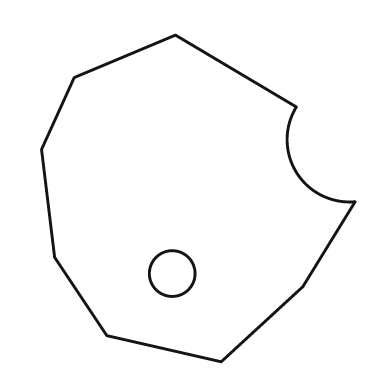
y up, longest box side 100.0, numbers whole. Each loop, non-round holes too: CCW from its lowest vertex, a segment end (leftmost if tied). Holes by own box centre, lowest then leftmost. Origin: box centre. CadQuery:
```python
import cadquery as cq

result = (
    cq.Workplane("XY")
    .moveTo(7.0, -50.0)
    .lineTo(32.0, -27.0)
    .lineTo(48.0, -1.0)
    .threePointArc((30.0, 8.0), (30.0, 28.0))
    .lineTo(-7.0, 50.0)
    .lineTo(-38.0, 37.0)
    .lineTo(-48.0, 15.0)
    .lineTo(-44.0, -18.0)
    .lineTo(-28.0, -42.0)
    .close()
    .moveTo(-8.0, -23.0)
    .circle(7.0)
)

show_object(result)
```